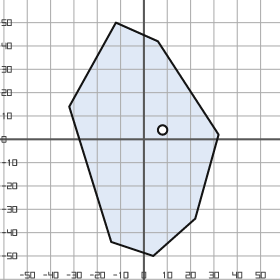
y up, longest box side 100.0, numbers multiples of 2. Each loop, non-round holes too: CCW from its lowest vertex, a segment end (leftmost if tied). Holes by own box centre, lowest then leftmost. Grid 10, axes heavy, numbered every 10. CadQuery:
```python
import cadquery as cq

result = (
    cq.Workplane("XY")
    .moveTo(4.0, -50.0)
    .lineTo(22.0, -34.0)
    .lineTo(32.0, 2.0)
    .lineTo(6.0, 42.0)
    .lineTo(-12.0, 50.0)
    .lineTo(-32.0, 14.0)
    .lineTo(-14.0, -44.0)
    .close()
    .moveTo(8.0, 4.0)
    .circle(2.0)
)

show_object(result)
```